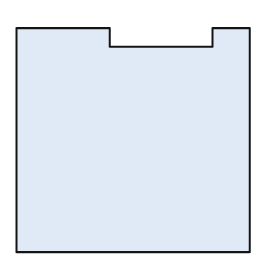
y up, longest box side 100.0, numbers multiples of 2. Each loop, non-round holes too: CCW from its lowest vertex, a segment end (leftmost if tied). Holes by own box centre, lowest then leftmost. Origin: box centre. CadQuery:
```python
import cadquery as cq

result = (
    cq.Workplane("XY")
    .moveTo(-50.0, -48.0)
    .lineTo(50.0, -48.0)
    .lineTo(50.0, 48.0)
    .lineTo(34.0, 48.0)
    .lineTo(34.0, 40.0)
    .lineTo(-10.0, 40.0)
    .lineTo(-10.0, 48.0)
    .lineTo(-50.0, 48.0)
    .close()
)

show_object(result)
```